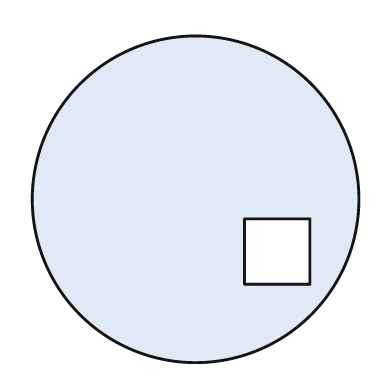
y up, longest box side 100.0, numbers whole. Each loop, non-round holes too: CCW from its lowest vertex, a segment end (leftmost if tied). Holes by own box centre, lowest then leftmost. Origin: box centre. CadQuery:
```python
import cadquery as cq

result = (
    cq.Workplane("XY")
    .moveTo(0.0, 0.0)
    .circle(50.0)
    .moveTo(15.0, -26.0)
    .lineTo(35.0, -26.0)
    .lineTo(35.0, -6.0)
    .lineTo(15.0, -6.0)
    .close()
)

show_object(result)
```